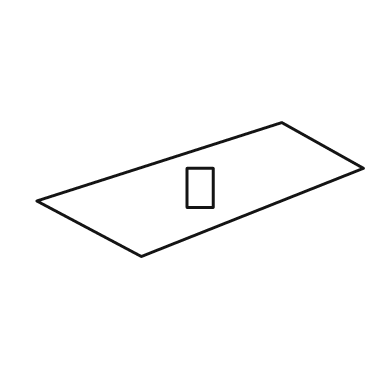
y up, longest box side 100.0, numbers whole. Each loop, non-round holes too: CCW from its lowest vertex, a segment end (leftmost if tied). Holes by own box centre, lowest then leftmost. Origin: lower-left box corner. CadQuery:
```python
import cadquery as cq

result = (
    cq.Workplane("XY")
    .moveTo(32.0, 0.0)
    .lineTo(100.0, 27.0)
    .lineTo(75.0, 41.0)
    .lineTo(0.0, 17.0)
    .close()
    .moveTo(46.0, 15.0)
    .lineTo(54.0, 15.0)
    .lineTo(54.0, 27.0)
    .lineTo(46.0, 27.0)
    .close()
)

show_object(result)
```